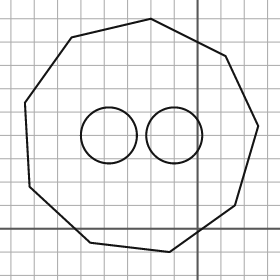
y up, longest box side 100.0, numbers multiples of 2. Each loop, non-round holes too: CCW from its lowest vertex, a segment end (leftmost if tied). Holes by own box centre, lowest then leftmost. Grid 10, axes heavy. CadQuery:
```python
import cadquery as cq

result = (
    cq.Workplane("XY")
    .moveTo(-12.0, -10.0)
    .lineTo(16.0, 10.0)
    .lineTo(26.0, 44.0)
    .lineTo(12.0, 74.0)
    .lineTo(-20.0, 90.0)
    .lineTo(-54.0, 82.0)
    .lineTo(-74.0, 54.0)
    .lineTo(-72.0, 18.0)
    .lineTo(-46.0, -6.0)
    .close()
    .moveTo(-38.0, 40.0)
    .circle(12.0)
    .moveTo(-10.0, 40.0)
    .circle(12.0)
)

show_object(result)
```